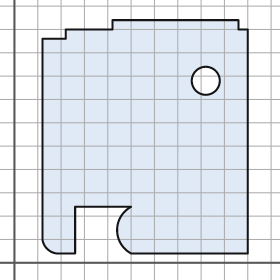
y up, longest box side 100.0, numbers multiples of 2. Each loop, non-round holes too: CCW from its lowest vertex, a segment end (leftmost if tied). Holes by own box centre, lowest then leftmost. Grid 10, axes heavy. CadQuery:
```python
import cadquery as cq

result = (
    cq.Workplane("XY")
    .moveTo(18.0, 4.0)
    .lineTo(26.0, 4.0)
    .lineTo(26.0, 24.0)
    .lineTo(50.0, 24.0)
    .threePointArc((44.0, 14.0), (50.0, 4.0))
    .lineTo(100.0, 4.0)
    .lineTo(100.0, 100.0)
    .lineTo(96.0, 100.0)
    .lineTo(96.0, 104.0)
    .lineTo(42.0, 104.0)
    .lineTo(42.0, 100.0)
    .lineTo(22.0, 100.0)
    .lineTo(22.0, 96.0)
    .lineTo(12.0, 96.0)
    .lineTo(12.0, 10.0)
    .threePointArc((14.0, 6.0), (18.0, 4.0))
    .close()
    .moveTo(82.0, 78.0)
    .circle(6.0)
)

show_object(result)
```